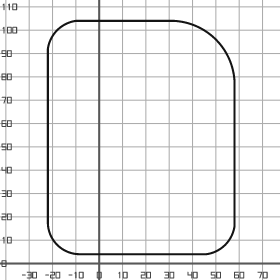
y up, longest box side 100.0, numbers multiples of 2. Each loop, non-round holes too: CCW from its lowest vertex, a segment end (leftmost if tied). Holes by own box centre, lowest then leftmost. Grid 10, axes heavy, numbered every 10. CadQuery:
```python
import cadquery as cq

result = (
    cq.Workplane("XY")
    .moveTo(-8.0, 4.0)
    .lineTo(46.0, 4.0)
    .threePointArc((54.0, 8.0), (58.0, 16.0))
    .lineTo(58.0, 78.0)
    .threePointArc((50.0, 96.0), (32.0, 104.0))
    .lineTo(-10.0, 104.0)
    .threePointArc((-18.0, 100.0), (-22.0, 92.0))
    .lineTo(-22.0, 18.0)
    .threePointArc((-18.0, 8.0), (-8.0, 4.0))
    .close()
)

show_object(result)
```